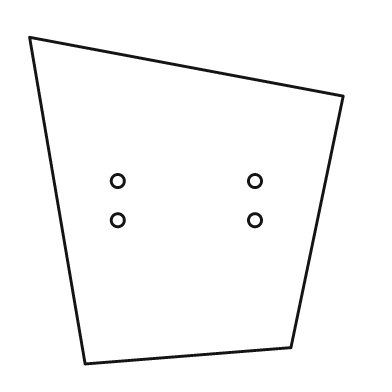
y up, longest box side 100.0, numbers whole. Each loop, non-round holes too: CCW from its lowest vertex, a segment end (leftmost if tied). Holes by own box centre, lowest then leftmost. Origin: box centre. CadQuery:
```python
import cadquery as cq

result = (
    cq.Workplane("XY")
    .moveTo(-31.0, -50.0)
    .lineTo(32.0, -45.0)
    .lineTo(48.0, 32.0)
    .lineTo(-48.0, 50.0)
    .close()
    .moveTo(-21.0, -6.0)
    .circle(2.0)
    .moveTo(21.0, -6.0)
    .circle(2.0)
    .moveTo(-21.0, 6.0)
    .circle(2.0)
    .moveTo(21.0, 6.0)
    .circle(2.0)
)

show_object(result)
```